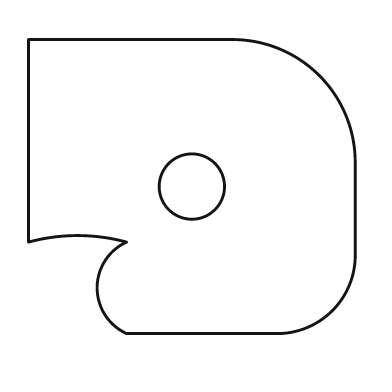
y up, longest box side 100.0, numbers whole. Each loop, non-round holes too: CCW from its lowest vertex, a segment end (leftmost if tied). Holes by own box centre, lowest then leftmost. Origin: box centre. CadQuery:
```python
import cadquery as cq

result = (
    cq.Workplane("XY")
    .moveTo(-20.0, -45.0)
    .lineTo(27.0, -45.0)
    .threePointArc((43.0, -38.0), (50.0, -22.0))
    .lineTo(50.0, 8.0)
    .threePointArc((39.0, 34.0), (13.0, 45.0))
    .lineTo(-50.0, 45.0)
    .lineTo(-50.0, -17.0)
    .threePointArc((-35.0, -15.0), (-20.0, -17.0))
    .threePointArc((-29.0, -31.0), (-20.0, -45.0))
    .close()
    .moveTo(0.0, 0.0)
    .circle(10.0)
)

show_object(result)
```